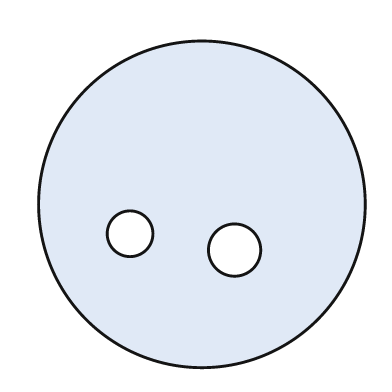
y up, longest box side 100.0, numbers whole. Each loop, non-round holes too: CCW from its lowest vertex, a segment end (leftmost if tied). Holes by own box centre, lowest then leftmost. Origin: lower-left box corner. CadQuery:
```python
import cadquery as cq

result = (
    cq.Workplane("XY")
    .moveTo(50.0, 50.0)
    .circle(50.0)
    .moveTo(60.0, 36.0)
    .circle(8.0)
    .moveTo(28.0, 41.0)
    .circle(7.0)
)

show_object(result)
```